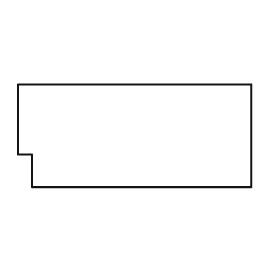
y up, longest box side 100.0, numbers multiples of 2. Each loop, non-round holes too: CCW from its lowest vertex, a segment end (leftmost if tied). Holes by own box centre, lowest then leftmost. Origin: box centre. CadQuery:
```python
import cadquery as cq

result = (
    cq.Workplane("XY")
    .moveTo(-44.0, -22.0)
    .lineTo(50.0, -22.0)
    .lineTo(50.0, 22.0)
    .lineTo(-50.0, 22.0)
    .lineTo(-50.0, -8.0)
    .lineTo(-44.0, -8.0)
    .close()
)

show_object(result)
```